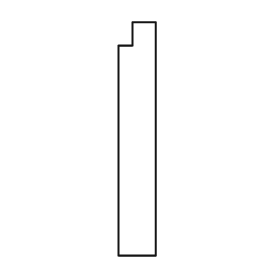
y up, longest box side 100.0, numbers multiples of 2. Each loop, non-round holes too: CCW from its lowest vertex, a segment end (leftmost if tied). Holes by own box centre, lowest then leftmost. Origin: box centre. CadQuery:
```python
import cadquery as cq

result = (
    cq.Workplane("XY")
    .moveTo(-8.0, -50.0)
    .lineTo(8.0, -50.0)
    .lineTo(8.0, 50.0)
    .lineTo(-2.0, 50.0)
    .lineTo(-2.0, 40.0)
    .lineTo(-8.0, 40.0)
    .close()
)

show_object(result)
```